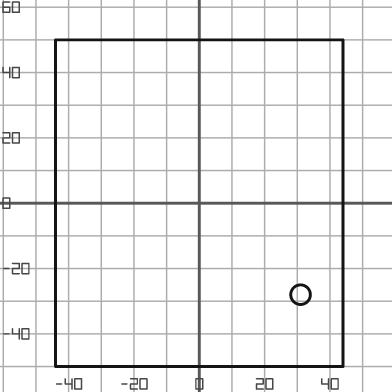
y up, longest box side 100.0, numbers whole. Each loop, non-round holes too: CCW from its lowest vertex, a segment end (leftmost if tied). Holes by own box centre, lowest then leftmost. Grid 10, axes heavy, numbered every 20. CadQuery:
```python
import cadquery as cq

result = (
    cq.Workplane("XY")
    .moveTo(-44.0, -50.0)
    .lineTo(44.0, -50.0)
    .lineTo(44.0, 50.0)
    .lineTo(-44.0, 50.0)
    .close()
    .moveTo(31.0, -28.0)
    .circle(3.0)
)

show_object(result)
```